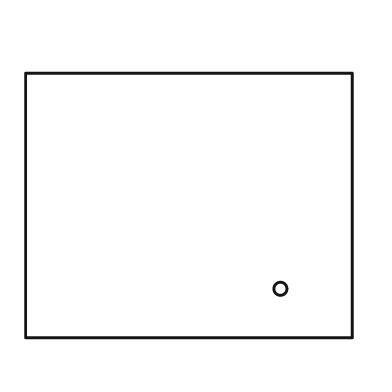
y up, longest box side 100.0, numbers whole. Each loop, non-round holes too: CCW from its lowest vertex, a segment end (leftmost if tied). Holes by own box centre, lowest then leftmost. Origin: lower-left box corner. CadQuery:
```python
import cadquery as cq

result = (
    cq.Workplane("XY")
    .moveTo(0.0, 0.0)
    .lineTo(100.0, 0.0)
    .lineTo(100.0, 81.0)
    .lineTo(0.0, 81.0)
    .close()
    .moveTo(78.0, 15.0)
    .circle(2.0)
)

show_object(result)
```